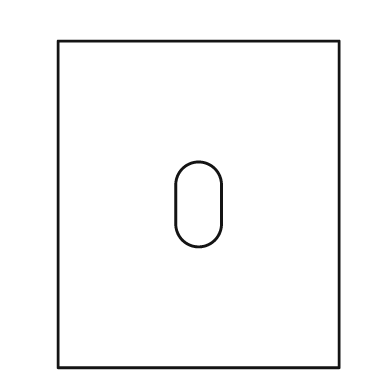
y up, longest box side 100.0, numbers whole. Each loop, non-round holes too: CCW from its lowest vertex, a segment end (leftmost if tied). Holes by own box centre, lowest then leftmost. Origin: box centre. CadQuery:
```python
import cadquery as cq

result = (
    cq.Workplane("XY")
    .moveTo(-43.0, -50.0)
    .lineTo(43.0, -50.0)
    .lineTo(43.0, 50.0)
    .lineTo(-43.0, 50.0)
    .close()
    .moveTo(-7.0, -6.0)
    .threePointArc((0.0, -13.0), (7.0, -6.0))
    .lineTo(7.0, 6.0)
    .threePointArc((0.0, 13.0), (-7.0, 6.0))
    .close()
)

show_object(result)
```